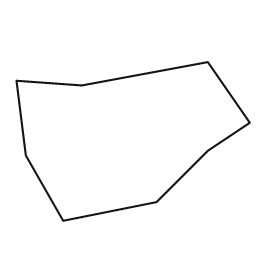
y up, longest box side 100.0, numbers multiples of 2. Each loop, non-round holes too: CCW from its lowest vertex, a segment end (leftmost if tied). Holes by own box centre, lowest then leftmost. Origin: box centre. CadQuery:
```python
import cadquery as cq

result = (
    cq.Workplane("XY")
    .moveTo(-30.0, -34.0)
    .lineTo(10.0, -26.0)
    .lineTo(32.0, -4.0)
    .lineTo(50.0, 8.0)
    .lineTo(32.0, 34.0)
    .lineTo(-22.0, 24.0)
    .lineTo(-50.0, 26.0)
    .lineTo(-46.0, -6.0)
    .close()
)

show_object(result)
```